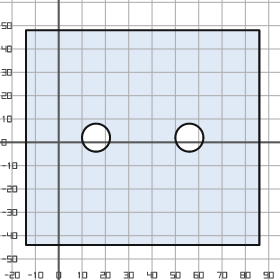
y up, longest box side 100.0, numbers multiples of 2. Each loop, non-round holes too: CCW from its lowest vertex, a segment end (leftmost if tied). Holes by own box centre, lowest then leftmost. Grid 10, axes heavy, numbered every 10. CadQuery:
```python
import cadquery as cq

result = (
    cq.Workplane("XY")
    .moveTo(-14.0, -44.0)
    .lineTo(86.0, -44.0)
    .lineTo(86.0, 48.0)
    .lineTo(-14.0, 48.0)
    .close()
    .moveTo(16.0, 2.0)
    .circle(6.0)
    .moveTo(56.0, 2.0)
    .circle(6.0)
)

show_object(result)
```